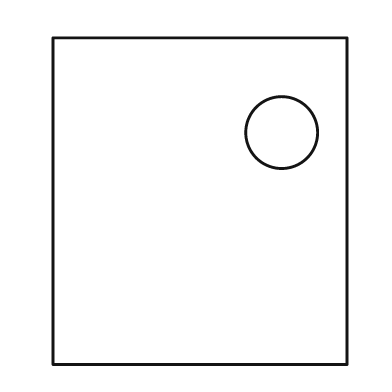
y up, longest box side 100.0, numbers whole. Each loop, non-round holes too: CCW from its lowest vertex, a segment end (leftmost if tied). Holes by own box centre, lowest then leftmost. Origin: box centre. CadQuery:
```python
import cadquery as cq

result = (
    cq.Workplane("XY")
    .moveTo(-45.0, -50.0)
    .lineTo(45.0, -50.0)
    .lineTo(45.0, 50.0)
    .lineTo(-45.0, 50.0)
    .close()
    .moveTo(25.0, 21.0)
    .circle(11.0)
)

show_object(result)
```